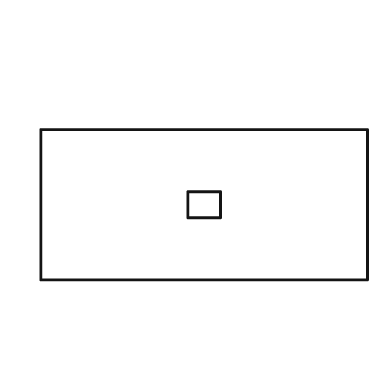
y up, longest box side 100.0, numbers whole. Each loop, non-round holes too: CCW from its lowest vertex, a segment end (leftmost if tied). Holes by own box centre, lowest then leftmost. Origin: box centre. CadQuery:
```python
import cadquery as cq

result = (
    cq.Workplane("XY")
    .moveTo(-50.0, -23.0)
    .lineTo(50.0, -23.0)
    .lineTo(50.0, 23.0)
    .lineTo(-50.0, 23.0)
    .close()
    .moveTo(-5.0, -4.0)
    .lineTo(5.0, -4.0)
    .lineTo(5.0, 4.0)
    .lineTo(-5.0, 4.0)
    .close()
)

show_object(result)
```